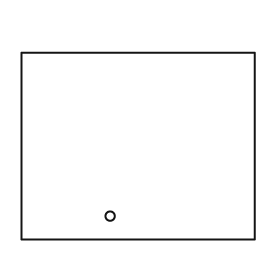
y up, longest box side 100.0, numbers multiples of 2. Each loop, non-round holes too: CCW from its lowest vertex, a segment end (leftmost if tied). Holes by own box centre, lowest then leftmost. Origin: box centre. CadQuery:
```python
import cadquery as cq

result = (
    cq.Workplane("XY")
    .moveTo(-50.0, -40.0)
    .lineTo(50.0, -40.0)
    .lineTo(50.0, 40.0)
    .lineTo(-50.0, 40.0)
    .close()
    .moveTo(-12.0, -30.0)
    .circle(2.0)
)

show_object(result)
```